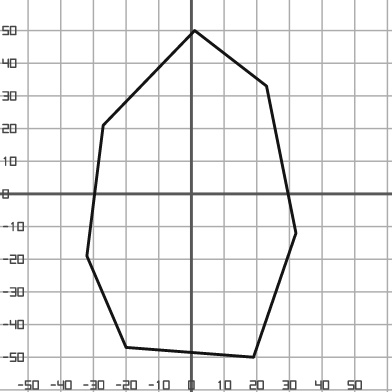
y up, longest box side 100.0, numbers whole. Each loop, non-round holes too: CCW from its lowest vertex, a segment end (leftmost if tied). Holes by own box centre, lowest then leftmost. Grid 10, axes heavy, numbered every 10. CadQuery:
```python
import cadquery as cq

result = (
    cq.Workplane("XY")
    .moveTo(19.0, -50.0)
    .lineTo(32.0, -12.0)
    .lineTo(23.0, 33.0)
    .lineTo(1.0, 50.0)
    .lineTo(-27.0, 21.0)
    .lineTo(-32.0, -19.0)
    .lineTo(-20.0, -47.0)
    .close()
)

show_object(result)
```